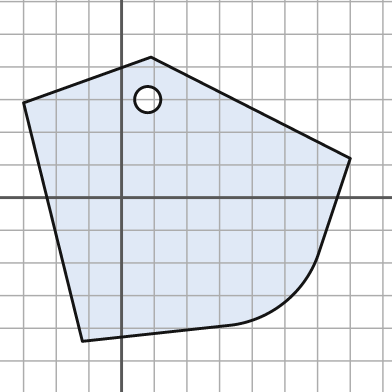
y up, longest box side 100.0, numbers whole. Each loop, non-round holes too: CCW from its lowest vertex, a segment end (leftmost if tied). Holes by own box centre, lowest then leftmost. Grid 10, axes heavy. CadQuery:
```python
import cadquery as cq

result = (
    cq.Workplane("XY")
    .moveTo(-12.0, -44.0)
    .lineTo(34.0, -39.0)
    .threePointArc((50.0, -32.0), (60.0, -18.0))
    .lineTo(70.0, 12.0)
    .lineTo(9.0, 43.0)
    .lineTo(-30.0, 29.0)
    .close()
    .moveTo(8.0, 30.0)
    .circle(4.0)
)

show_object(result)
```